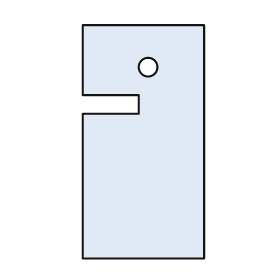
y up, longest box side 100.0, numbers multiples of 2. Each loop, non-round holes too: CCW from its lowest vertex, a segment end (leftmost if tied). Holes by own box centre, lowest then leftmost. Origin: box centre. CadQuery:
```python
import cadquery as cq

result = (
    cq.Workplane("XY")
    .moveTo(-26.0, -50.0)
    .lineTo(26.0, -50.0)
    .lineTo(26.0, 50.0)
    .lineTo(-26.0, 50.0)
    .lineTo(-26.0, 20.0)
    .lineTo(-2.0, 20.0)
    .lineTo(-2.0, 12.0)
    .lineTo(-26.0, 12.0)
    .close()
    .moveTo(2.0, 32.0)
    .circle(4.0)
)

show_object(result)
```